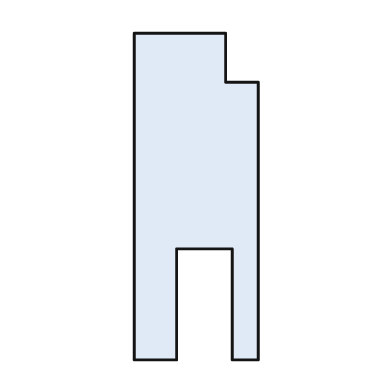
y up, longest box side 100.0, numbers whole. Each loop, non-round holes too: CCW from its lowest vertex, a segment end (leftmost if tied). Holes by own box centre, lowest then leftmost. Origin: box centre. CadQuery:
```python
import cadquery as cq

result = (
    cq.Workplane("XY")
    .moveTo(-19.0, -50.0)
    .lineTo(-6.0, -50.0)
    .lineTo(-6.0, -16.0)
    .lineTo(11.0, -16.0)
    .lineTo(11.0, -50.0)
    .lineTo(19.0, -50.0)
    .lineTo(19.0, 35.0)
    .lineTo(9.0, 35.0)
    .lineTo(9.0, 50.0)
    .lineTo(-19.0, 50.0)
    .close()
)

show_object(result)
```